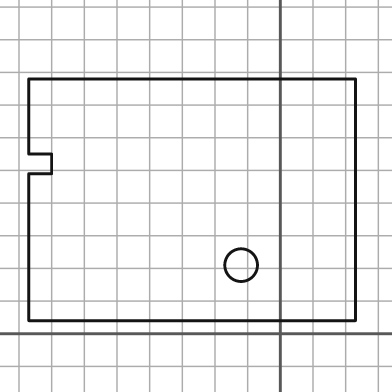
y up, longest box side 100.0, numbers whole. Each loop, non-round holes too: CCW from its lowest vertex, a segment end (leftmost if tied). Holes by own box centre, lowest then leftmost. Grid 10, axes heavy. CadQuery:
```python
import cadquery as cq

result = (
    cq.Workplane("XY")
    .moveTo(-77.0, 4.0)
    .lineTo(23.0, 4.0)
    .lineTo(23.0, 78.0)
    .lineTo(-77.0, 78.0)
    .lineTo(-77.0, 55.0)
    .lineTo(-70.0, 55.0)
    .lineTo(-70.0, 49.0)
    .lineTo(-77.0, 49.0)
    .close()
    .moveTo(-12.0, 21.0)
    .circle(5.0)
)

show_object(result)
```